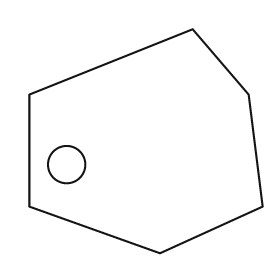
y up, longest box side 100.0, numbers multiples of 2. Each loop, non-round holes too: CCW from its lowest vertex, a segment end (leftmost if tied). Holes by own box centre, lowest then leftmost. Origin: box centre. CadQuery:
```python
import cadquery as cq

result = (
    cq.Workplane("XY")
    .moveTo(6.0, -48.0)
    .lineTo(50.0, -28.0)
    .lineTo(44.0, 20.0)
    .lineTo(20.0, 48.0)
    .lineTo(-50.0, 20.0)
    .lineTo(-50.0, -28.0)
    .close()
    .moveTo(-34.0, -10.0)
    .circle(8.0)
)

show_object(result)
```